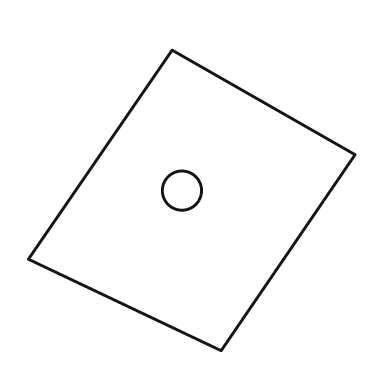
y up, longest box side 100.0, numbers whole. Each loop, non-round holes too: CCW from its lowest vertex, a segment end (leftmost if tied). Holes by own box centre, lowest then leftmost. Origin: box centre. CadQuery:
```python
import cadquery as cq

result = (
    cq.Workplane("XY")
    .moveTo(9.0, -46.0)
    .lineTo(50.0, 14.0)
    .lineTo(-6.0, 46.0)
    .lineTo(-50.0, -18.0)
    .close()
    .moveTo(-3.0, 3.0)
    .circle(6.0)
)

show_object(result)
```